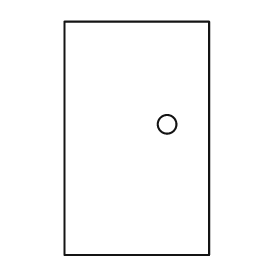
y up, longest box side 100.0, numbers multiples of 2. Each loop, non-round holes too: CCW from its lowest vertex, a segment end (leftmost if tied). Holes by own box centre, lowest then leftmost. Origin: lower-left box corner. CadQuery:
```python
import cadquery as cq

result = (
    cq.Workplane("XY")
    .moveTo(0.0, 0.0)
    .lineTo(62.0, 0.0)
    .lineTo(62.0, 100.0)
    .lineTo(0.0, 100.0)
    .close()
    .moveTo(44.0, 56.0)
    .circle(4.0)
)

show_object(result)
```